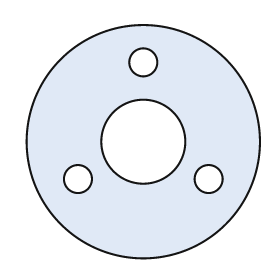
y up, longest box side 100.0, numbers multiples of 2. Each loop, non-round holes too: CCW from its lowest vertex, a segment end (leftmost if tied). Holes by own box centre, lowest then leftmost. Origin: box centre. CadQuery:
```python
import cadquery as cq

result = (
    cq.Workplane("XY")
    .moveTo(0.0, 0.0)
    .circle(50.0)
    .moveTo(-28.0, -16.0)
    .circle(6.0)
    .moveTo(28.0, -16.0)
    .circle(6.0)
    .moveTo(0.0, 0.0)
    .circle(18.0)
    .moveTo(0.0, 34.0)
    .circle(6.0)
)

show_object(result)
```